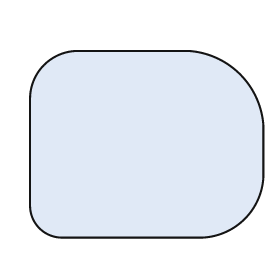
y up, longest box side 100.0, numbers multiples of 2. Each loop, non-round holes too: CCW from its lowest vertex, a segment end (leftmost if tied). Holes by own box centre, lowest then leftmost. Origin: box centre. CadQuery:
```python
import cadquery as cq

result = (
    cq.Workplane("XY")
    .moveTo(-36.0, -40.0)
    .lineTo(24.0, -40.0)
    .threePointArc((42.0, -32.0), (50.0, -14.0))
    .lineTo(50.0, 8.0)
    .threePointArc((40.0, 30.0), (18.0, 40.0))
    .lineTo(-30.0, 40.0)
    .threePointArc((-44.0, 34.0), (-50.0, 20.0))
    .lineTo(-50.0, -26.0)
    .threePointArc((-46.0, -36.0), (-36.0, -40.0))
    .close()
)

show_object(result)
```